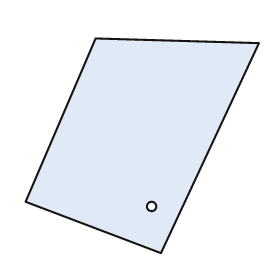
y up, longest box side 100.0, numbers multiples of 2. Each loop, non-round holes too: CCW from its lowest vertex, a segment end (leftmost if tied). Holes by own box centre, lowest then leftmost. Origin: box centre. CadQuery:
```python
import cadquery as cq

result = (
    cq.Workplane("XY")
    .moveTo(8.0, -46.0)
    .lineTo(50.0, 44.0)
    .lineTo(-20.0, 46.0)
    .lineTo(-50.0, -24.0)
    .close()
    .moveTo(4.0, -26.0)
    .circle(2.0)
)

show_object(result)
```